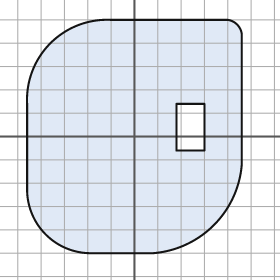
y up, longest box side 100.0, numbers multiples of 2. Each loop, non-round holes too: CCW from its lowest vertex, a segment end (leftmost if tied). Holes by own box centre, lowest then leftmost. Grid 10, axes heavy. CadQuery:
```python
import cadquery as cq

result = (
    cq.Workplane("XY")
    .moveTo(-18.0, -50.0)
    .lineTo(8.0, -50.0)
    .threePointArc((34.0, -38.0), (46.0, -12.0))
    .lineTo(46.0, 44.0)
    .threePointArc((44.0, 48.0), (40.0, 50.0))
    .lineTo(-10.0, 50.0)
    .threePointArc((-36.0, 40.0), (-46.0, 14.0))
    .lineTo(-46.0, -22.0)
    .threePointArc((-38.0, -42.0), (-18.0, -50.0))
    .close()
    .moveTo(18.0, -6.0)
    .lineTo(30.0, -6.0)
    .lineTo(30.0, 14.0)
    .lineTo(18.0, 14.0)
    .close()
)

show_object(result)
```